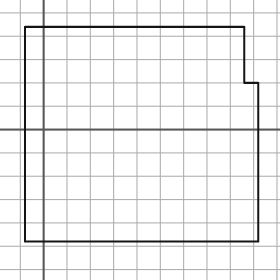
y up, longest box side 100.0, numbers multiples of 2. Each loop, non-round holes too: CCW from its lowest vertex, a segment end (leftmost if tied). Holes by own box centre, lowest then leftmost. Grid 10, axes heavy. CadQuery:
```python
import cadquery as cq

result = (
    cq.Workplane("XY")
    .moveTo(-8.0, -48.0)
    .lineTo(92.0, -48.0)
    .lineTo(92.0, 20.0)
    .lineTo(86.0, 20.0)
    .lineTo(86.0, 44.0)
    .lineTo(-8.0, 44.0)
    .close()
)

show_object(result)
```